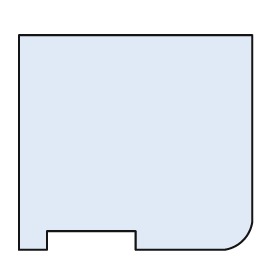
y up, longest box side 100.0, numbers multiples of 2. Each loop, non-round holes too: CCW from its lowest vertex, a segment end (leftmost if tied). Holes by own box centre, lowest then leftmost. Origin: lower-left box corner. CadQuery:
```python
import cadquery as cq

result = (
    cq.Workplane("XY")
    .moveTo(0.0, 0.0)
    .lineTo(12.0, 0.0)
    .lineTo(12.0, 8.0)
    .lineTo(50.0, 8.0)
    .lineTo(50.0, 0.0)
    .lineTo(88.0, 0.0)
    .threePointArc((96.0, 4.0), (100.0, 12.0))
    .lineTo(100.0, 92.0)
    .lineTo(0.0, 92.0)
    .close()
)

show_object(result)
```